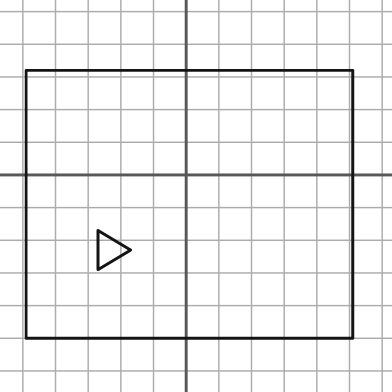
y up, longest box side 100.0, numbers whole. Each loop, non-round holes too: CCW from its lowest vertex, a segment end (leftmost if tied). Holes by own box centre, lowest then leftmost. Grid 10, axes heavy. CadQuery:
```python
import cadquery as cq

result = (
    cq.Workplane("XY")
    .moveTo(-49.0, -50.0)
    .lineTo(51.0, -50.0)
    .lineTo(51.0, 32.0)
    .lineTo(-49.0, 32.0)
    .close()
    .moveTo(-27.0, -29.0)
    .lineTo(-17.0, -23.0)
    .lineTo(-27.0, -17.0)
    .close()
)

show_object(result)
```